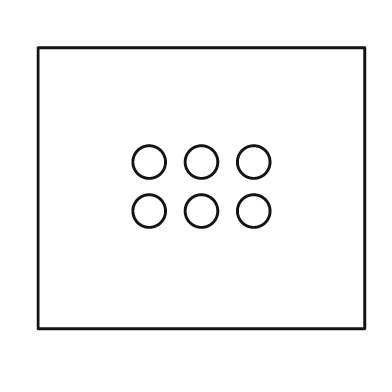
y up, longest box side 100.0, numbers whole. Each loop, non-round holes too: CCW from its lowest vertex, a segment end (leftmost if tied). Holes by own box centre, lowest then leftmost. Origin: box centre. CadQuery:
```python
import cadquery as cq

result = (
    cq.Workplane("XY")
    .moveTo(-50.0, -43.0)
    .lineTo(50.0, -43.0)
    .lineTo(50.0, 43.0)
    .lineTo(-50.0, 43.0)
    .close()
    .moveTo(-16.0, -7.0)
    .circle(5.0)
    .moveTo(0.0, -7.0)
    .circle(5.0)
    .moveTo(16.0, -7.0)
    .circle(5.0)
    .moveTo(-16.0, 8.0)
    .circle(5.0)
    .moveTo(0.0, 8.0)
    .circle(5.0)
    .moveTo(16.0, 8.0)
    .circle(5.0)
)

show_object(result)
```